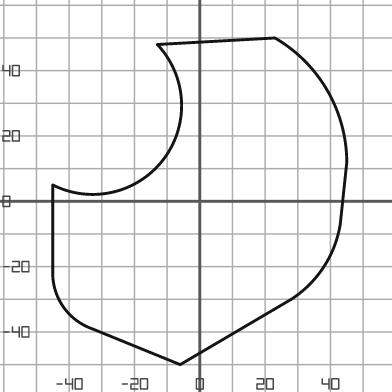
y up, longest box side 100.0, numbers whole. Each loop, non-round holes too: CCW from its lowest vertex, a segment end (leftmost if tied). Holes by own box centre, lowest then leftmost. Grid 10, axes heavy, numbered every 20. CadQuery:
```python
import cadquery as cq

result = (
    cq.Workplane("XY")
    .moveTo(-6.0, -50.0)
    .lineTo(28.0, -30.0)
    .threePointArc((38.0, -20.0), (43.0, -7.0))
    .lineTo(45.0, 12.0)
    .threePointArc((39.0, 34.0), (23.0, 50.0))
    .lineTo(-13.0, 48.0)
    .threePointArc((-11.0, 13.0), (-45.0, 5.0))
    .lineTo(-45.0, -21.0)
    .threePointArc((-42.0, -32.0), (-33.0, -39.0))
    .close()
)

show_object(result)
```